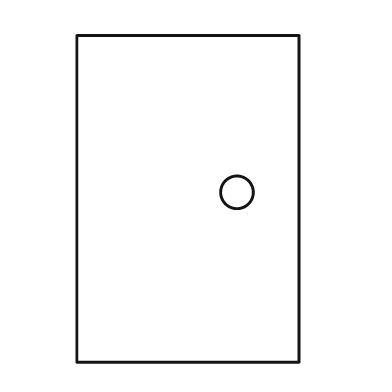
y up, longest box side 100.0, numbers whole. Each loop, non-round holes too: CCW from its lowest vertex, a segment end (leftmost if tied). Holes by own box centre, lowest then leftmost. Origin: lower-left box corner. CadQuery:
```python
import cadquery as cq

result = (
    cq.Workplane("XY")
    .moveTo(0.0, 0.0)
    .lineTo(68.0, 0.0)
    .lineTo(68.0, 100.0)
    .lineTo(0.0, 100.0)
    .close()
    .moveTo(49.0, 52.0)
    .circle(5.0)
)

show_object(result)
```